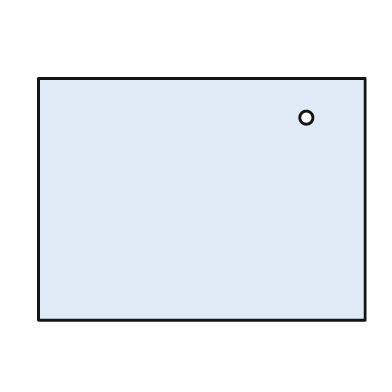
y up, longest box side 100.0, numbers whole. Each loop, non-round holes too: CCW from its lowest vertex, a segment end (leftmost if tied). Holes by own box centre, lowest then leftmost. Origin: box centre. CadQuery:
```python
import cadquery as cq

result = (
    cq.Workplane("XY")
    .moveTo(-50.0, -37.0)
    .lineTo(50.0, -37.0)
    .lineTo(50.0, 37.0)
    .lineTo(-50.0, 37.0)
    .close()
    .moveTo(32.0, 25.0)
    .circle(2.0)
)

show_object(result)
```